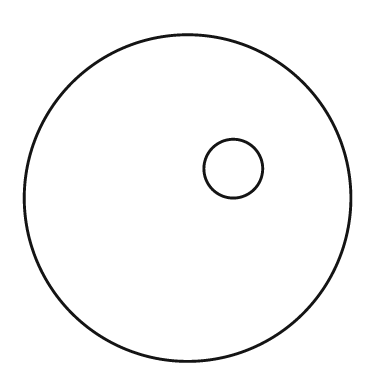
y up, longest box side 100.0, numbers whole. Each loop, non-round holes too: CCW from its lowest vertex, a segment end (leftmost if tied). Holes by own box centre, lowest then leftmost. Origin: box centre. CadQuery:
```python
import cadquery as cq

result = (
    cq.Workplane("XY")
    .moveTo(0.0, 0.0)
    .circle(50.0)
    .moveTo(14.0, 9.0)
    .circle(9.0)
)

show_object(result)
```